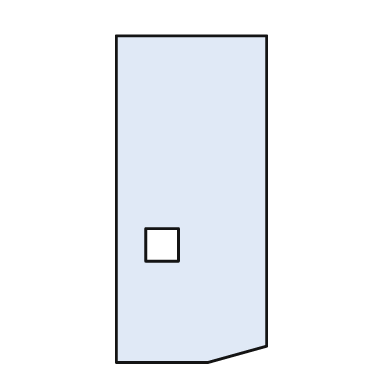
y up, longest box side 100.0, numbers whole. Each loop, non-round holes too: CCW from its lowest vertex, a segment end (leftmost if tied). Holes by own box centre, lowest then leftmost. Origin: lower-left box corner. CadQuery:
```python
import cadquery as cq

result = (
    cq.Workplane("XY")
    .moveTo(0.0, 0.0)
    .lineTo(28.0, 0.0)
    .lineTo(46.0, 5.0)
    .lineTo(46.0, 100.0)
    .lineTo(0.0, 100.0)
    .close()
    .moveTo(9.0, 31.0)
    .lineTo(19.0, 31.0)
    .lineTo(19.0, 41.0)
    .lineTo(9.0, 41.0)
    .close()
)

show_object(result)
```